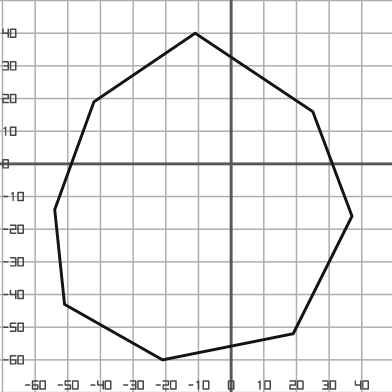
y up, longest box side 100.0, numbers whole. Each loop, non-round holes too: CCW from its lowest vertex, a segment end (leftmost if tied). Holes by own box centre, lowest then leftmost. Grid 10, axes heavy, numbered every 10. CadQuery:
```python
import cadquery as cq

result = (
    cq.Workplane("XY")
    .moveTo(-21.0, -60.0)
    .lineTo(19.0, -52.0)
    .lineTo(37.0, -16.0)
    .lineTo(25.0, 16.0)
    .lineTo(-11.0, 40.0)
    .lineTo(-42.0, 19.0)
    .lineTo(-54.0, -14.0)
    .lineTo(-51.0, -43.0)
    .close()
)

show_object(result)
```